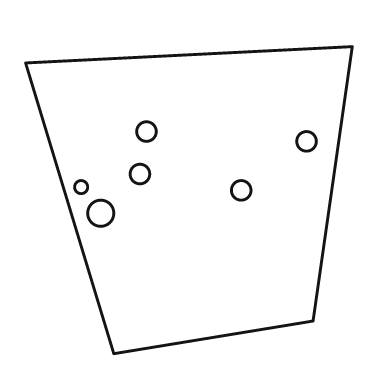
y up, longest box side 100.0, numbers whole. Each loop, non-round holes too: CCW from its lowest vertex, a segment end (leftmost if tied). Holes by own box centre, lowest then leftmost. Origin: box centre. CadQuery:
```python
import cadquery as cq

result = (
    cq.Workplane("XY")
    .moveTo(-23.0, -47.0)
    .lineTo(38.0, -37.0)
    .lineTo(50.0, 47.0)
    .lineTo(-50.0, 42.0)
    .close()
    .moveTo(-27.0, -4.0)
    .circle(4.0)
    .moveTo(16.0, 3.0)
    .circle(3.0)
    .moveTo(-33.0, 4.0)
    .circle(2.0)
    .moveTo(-15.0, 8.0)
    .circle(3.0)
    .moveTo(36.0, 18.0)
    .circle(3.0)
    .moveTo(-13.0, 21.0)
    .circle(3.0)
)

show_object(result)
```